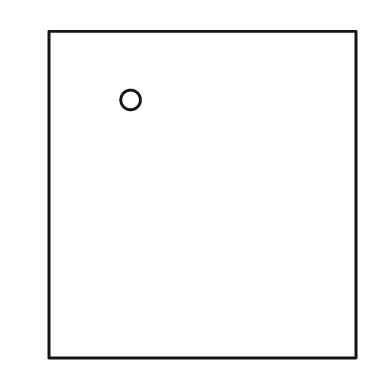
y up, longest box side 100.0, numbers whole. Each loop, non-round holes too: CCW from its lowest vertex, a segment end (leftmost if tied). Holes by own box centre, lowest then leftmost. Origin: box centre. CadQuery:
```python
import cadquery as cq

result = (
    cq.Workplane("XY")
    .moveTo(-47.0, -50.0)
    .lineTo(47.0, -50.0)
    .lineTo(47.0, 50.0)
    .lineTo(-47.0, 50.0)
    .close()
    .moveTo(-22.0, 29.0)
    .circle(3.0)
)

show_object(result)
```